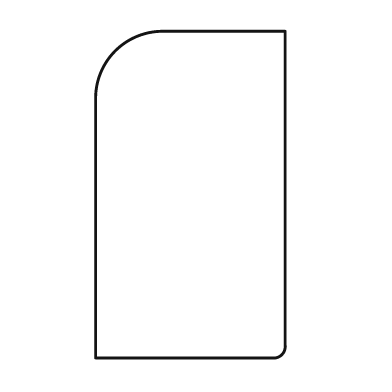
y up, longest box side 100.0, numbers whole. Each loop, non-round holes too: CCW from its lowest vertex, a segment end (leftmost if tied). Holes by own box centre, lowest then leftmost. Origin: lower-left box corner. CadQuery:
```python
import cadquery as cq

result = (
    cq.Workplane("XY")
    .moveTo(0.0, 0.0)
    .lineTo(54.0, 0.0)
    .threePointArc((57.0, 1.0), (58.0, 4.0))
    .lineTo(58.0, 100.0)
    .lineTo(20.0, 100.0)
    .threePointArc((6.0, 94.0), (0.0, 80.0))
    .close()
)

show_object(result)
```